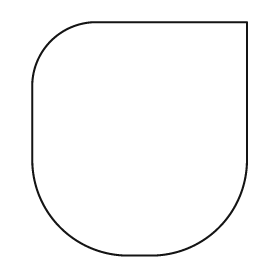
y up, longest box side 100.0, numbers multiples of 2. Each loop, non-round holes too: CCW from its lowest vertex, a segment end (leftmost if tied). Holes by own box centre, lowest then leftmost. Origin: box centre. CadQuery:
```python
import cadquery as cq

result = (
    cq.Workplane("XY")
    .moveTo(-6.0, -50.0)
    .lineTo(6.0, -50.0)
    .threePointArc((34.0, -38.0), (46.0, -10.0))
    .lineTo(46.0, 50.0)
    .lineTo(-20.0, 50.0)
    .threePointArc((-38.0, 42.0), (-46.0, 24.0))
    .lineTo(-46.0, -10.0)
    .threePointArc((-34.0, -38.0), (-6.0, -50.0))
    .close()
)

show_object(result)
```